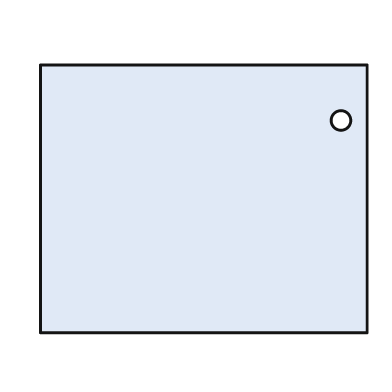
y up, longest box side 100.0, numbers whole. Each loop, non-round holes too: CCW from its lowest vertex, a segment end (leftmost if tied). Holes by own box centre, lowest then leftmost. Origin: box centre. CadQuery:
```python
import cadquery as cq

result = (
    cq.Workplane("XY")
    .moveTo(-50.0, -41.0)
    .lineTo(50.0, -41.0)
    .lineTo(50.0, 41.0)
    .lineTo(-50.0, 41.0)
    .close()
    .moveTo(42.0, 24.0)
    .circle(3.0)
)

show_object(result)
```